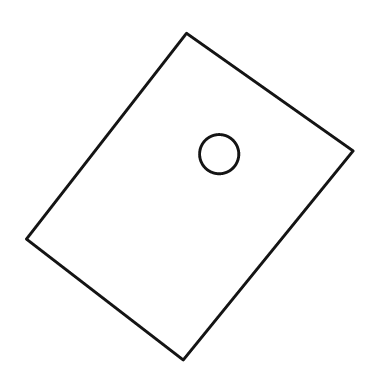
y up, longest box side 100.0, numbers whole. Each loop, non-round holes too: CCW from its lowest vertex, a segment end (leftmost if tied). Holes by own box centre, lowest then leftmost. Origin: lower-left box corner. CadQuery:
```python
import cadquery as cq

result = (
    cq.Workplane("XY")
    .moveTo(48.0, 0.0)
    .lineTo(100.0, 64.0)
    .lineTo(49.0, 100.0)
    .lineTo(0.0, 37.0)
    .close()
    .moveTo(59.0, 63.0)
    .circle(6.0)
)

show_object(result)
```